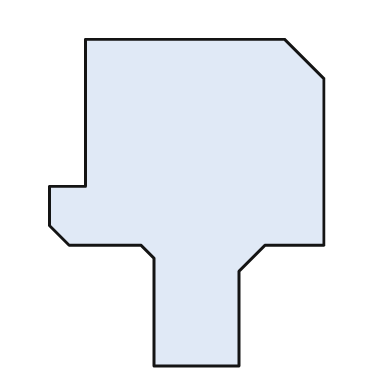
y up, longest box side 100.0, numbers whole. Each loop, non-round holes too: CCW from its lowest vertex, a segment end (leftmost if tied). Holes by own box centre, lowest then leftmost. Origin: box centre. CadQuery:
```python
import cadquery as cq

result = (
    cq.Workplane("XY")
    .moveTo(-10.0, -50.0)
    .lineTo(16.0, -50.0)
    .lineTo(16.0, -21.0)
    .lineTo(24.0, -13.0)
    .lineTo(42.0, -13.0)
    .lineTo(42.0, 38.0)
    .lineTo(30.0, 50.0)
    .lineTo(-31.0, 50.0)
    .lineTo(-31.0, 5.0)
    .lineTo(-42.0, 5.0)
    .lineTo(-42.0, -7.0)
    .lineTo(-36.0, -13.0)
    .lineTo(-14.0, -13.0)
    .lineTo(-10.0, -17.0)
    .close()
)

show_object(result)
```